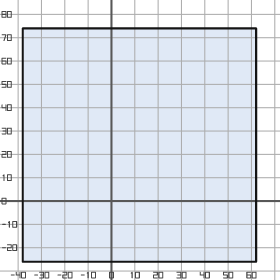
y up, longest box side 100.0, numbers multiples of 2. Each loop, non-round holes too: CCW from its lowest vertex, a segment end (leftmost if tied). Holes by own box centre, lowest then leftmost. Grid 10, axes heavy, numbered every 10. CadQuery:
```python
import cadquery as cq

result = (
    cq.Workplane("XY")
    .moveTo(-38.0, -26.0)
    .lineTo(62.0, -26.0)
    .lineTo(62.0, 74.0)
    .lineTo(-38.0, 74.0)
    .close()
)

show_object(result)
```